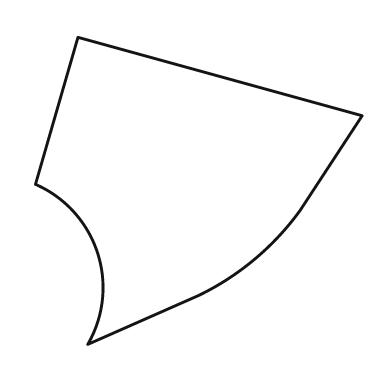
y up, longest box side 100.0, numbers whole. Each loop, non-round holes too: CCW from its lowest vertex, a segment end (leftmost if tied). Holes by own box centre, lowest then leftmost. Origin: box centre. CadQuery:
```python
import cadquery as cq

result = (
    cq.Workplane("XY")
    .moveTo(-34.0, -47.0)
    .lineTo(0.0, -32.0)
    .threePointArc((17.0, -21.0), (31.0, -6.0))
    .lineTo(50.0, 23.0)
    .lineTo(-37.0, 47.0)
    .lineTo(-50.0, 2.0)
    .threePointArc((-31.0, -19.0), (-34.0, -47.0))
    .close()
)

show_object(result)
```